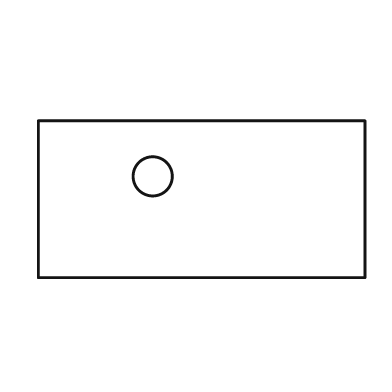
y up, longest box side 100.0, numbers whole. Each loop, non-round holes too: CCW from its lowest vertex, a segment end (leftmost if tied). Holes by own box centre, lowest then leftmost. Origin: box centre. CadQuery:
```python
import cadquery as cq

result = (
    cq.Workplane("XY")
    .moveTo(-50.0, -24.0)
    .lineTo(50.0, -24.0)
    .lineTo(50.0, 24.0)
    .lineTo(-50.0, 24.0)
    .close()
    .moveTo(-15.0, 7.0)
    .circle(6.0)
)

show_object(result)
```